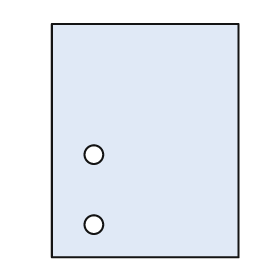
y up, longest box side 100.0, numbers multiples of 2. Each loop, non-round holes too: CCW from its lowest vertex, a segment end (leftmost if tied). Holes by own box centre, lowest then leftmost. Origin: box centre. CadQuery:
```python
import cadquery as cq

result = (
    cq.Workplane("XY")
    .moveTo(-40.0, -50.0)
    .lineTo(40.0, -50.0)
    .lineTo(40.0, 50.0)
    .lineTo(-40.0, 50.0)
    .close()
    .moveTo(-22.0, -36.0)
    .circle(4.0)
    .moveTo(-22.0, -6.0)
    .circle(4.0)
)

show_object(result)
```